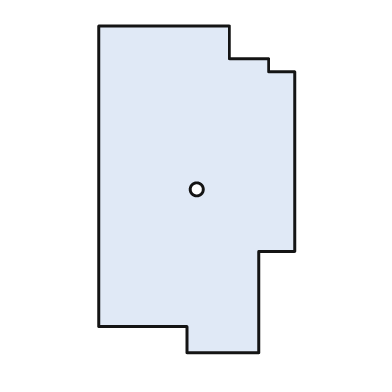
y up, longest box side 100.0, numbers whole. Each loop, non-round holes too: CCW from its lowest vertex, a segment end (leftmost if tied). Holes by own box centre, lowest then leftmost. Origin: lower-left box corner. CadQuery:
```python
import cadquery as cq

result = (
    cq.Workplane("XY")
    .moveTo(27.0, 0.0)
    .lineTo(49.0, 0.0)
    .lineTo(49.0, 31.0)
    .lineTo(60.0, 31.0)
    .lineTo(60.0, 86.0)
    .lineTo(52.0, 86.0)
    .lineTo(52.0, 90.0)
    .lineTo(40.0, 90.0)
    .lineTo(40.0, 100.0)
    .lineTo(0.0, 100.0)
    .lineTo(0.0, 8.0)
    .lineTo(27.0, 8.0)
    .close()
    .moveTo(30.0, 50.0)
    .circle(2.0)
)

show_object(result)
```